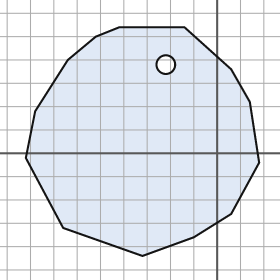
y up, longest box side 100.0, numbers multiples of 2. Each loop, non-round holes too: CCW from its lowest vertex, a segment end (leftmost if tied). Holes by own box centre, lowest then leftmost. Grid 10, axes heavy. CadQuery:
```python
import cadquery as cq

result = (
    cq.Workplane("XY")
    .moveTo(-32.0, -44.0)
    .lineTo(-10.0, -36.0)
    .lineTo(6.0, -26.0)
    .lineTo(18.0, -4.0)
    .lineTo(14.0, 22.0)
    .lineTo(6.0, 36.0)
    .lineTo(-14.0, 54.0)
    .lineTo(-42.0, 54.0)
    .lineTo(-52.0, 50.0)
    .lineTo(-64.0, 40.0)
    .lineTo(-78.0, 18.0)
    .lineTo(-82.0, -2.0)
    .lineTo(-66.0, -32.0)
    .close()
    .moveTo(-22.0, 38.0)
    .circle(4.0)
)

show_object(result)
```